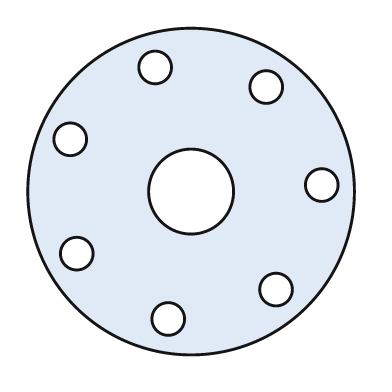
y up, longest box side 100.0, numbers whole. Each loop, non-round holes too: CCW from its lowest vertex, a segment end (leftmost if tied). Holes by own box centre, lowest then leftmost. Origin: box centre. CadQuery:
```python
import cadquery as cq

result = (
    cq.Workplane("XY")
    .moveTo(0.0, 0.0)
    .circle(50.0)
    .moveTo(-7.0, -39.0)
    .circle(5.0)
    .moveTo(26.0, -30.0)
    .circle(5.0)
    .moveTo(-35.0, -19.0)
    .circle(5.0)
    .moveTo(0.0, 0.0)
    .circle(13.0)
    .moveTo(40.0, 2.0)
    .circle(5.0)
    .moveTo(-37.0, 16.0)
    .circle(5.0)
    .moveTo(23.0, 32.0)
    .circle(5.0)
    .moveTo(-11.0, 38.0)
    .circle(5.0)
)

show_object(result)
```